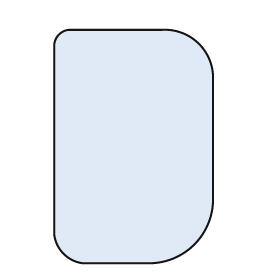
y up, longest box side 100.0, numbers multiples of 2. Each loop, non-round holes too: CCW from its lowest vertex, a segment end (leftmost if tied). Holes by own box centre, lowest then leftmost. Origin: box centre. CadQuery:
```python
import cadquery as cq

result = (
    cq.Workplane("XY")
    .moveTo(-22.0, -50.0)
    .lineTo(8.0, -50.0)
    .threePointArc((26.0, -42.0), (34.0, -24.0))
    .lineTo(34.0, 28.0)
    .threePointArc((28.0, 44.0), (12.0, 50.0))
    .lineTo(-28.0, 50.0)
    .threePointArc((-32.0, 48.0), (-34.0, 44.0))
    .lineTo(-34.0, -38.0)
    .threePointArc((-30.0, -46.0), (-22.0, -50.0))
    .close()
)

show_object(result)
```